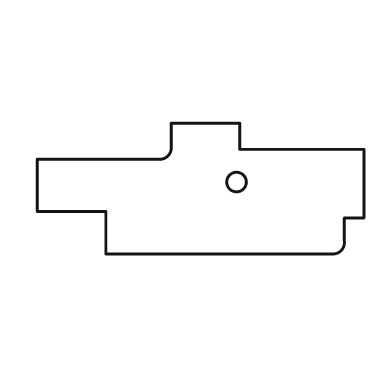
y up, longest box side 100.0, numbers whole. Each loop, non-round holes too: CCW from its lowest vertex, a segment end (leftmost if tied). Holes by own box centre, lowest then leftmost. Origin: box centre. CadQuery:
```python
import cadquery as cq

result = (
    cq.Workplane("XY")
    .moveTo(-29.0, -20.0)
    .lineTo(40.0, -20.0)
    .threePointArc((43.0, -19.0), (44.0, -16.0))
    .lineTo(44.0, -9.0)
    .lineTo(50.0, -9.0)
    .lineTo(50.0, 12.0)
    .lineTo(12.0, 12.0)
    .lineTo(12.0, 20.0)
    .lineTo(-9.0, 20.0)
    .lineTo(-9.0, 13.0)
    .threePointArc((-10.0, 10.0), (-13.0, 9.0))
    .lineTo(-50.0, 9.0)
    .lineTo(-50.0, -7.0)
    .lineTo(-29.0, -7.0)
    .close()
    .moveTo(11.0, 2.0)
    .circle(3.0)
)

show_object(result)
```